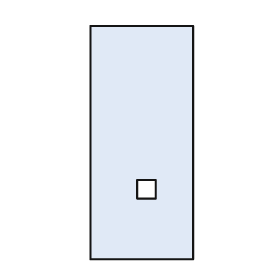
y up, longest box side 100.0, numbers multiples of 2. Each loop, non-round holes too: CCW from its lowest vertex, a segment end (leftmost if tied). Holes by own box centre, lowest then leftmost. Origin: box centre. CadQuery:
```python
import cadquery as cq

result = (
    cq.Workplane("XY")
    .moveTo(-22.0, -50.0)
    .lineTo(22.0, -50.0)
    .lineTo(22.0, 50.0)
    .lineTo(-22.0, 50.0)
    .close()
    .moveTo(-2.0, -24.0)
    .lineTo(6.0, -24.0)
    .lineTo(6.0, -16.0)
    .lineTo(-2.0, -16.0)
    .close()
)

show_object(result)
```